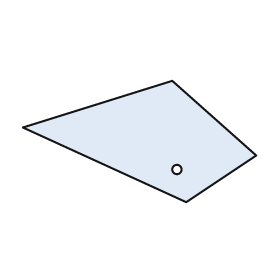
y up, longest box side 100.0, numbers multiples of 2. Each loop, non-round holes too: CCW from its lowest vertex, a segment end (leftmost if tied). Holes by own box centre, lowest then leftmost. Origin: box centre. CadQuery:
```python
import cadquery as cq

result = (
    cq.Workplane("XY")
    .moveTo(20.0, -26.0)
    .lineTo(50.0, -6.0)
    .lineTo(14.0, 26.0)
    .lineTo(-50.0, 6.0)
    .close()
    .moveTo(16.0, -12.0)
    .circle(2.0)
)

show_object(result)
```